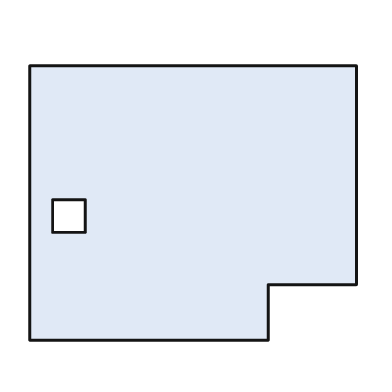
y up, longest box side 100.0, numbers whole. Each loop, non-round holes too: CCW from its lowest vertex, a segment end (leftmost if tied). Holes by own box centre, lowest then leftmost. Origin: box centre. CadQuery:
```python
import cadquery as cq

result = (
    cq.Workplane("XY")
    .moveTo(-50.0, -42.0)
    .lineTo(23.0, -42.0)
    .lineTo(23.0, -25.0)
    .lineTo(50.0, -25.0)
    .lineTo(50.0, 42.0)
    .lineTo(-50.0, 42.0)
    .close()
    .moveTo(-43.0, -9.0)
    .lineTo(-33.0, -9.0)
    .lineTo(-33.0, 1.0)
    .lineTo(-43.0, 1.0)
    .close()
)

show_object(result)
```